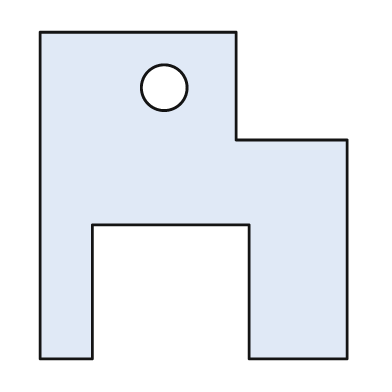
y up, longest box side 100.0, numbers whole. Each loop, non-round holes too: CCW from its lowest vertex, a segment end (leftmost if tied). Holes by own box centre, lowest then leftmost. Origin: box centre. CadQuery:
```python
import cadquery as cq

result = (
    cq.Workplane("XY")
    .moveTo(-47.0, -50.0)
    .lineTo(-31.0, -50.0)
    .lineTo(-31.0, -9.0)
    .lineTo(17.0, -9.0)
    .lineTo(17.0, -50.0)
    .lineTo(47.0, -50.0)
    .lineTo(47.0, 17.0)
    .lineTo(13.0, 17.0)
    .lineTo(13.0, 50.0)
    .lineTo(-47.0, 50.0)
    .close()
    .moveTo(-9.0, 33.0)
    .circle(7.0)
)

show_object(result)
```